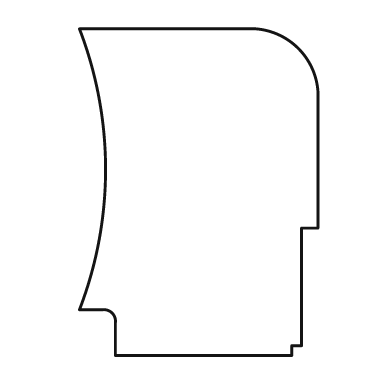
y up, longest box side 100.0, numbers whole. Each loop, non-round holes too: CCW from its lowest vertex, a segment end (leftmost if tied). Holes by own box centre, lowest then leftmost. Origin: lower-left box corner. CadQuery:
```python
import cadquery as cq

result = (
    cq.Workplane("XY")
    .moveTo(11.0, 0.0)
    .lineTo(65.0, 0.0)
    .lineTo(65.0, 3.0)
    .lineTo(68.0, 3.0)
    .lineTo(68.0, 39.0)
    .lineTo(73.0, 39.0)
    .lineTo(73.0, 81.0)
    .threePointArc((67.0, 94.0), (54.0, 100.0))
    .lineTo(0.0, 100.0)
    .threePointArc((8.0, 57.0), (0.0, 14.0))
    .lineTo(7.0, 14.0)
    .threePointArc((10.0, 13.0), (11.0, 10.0))
    .close()
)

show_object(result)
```